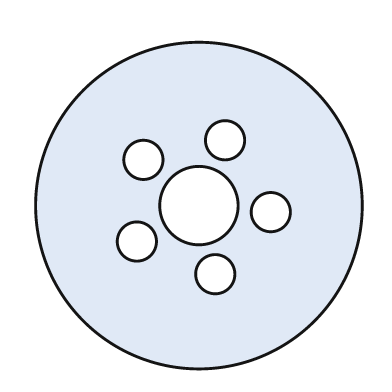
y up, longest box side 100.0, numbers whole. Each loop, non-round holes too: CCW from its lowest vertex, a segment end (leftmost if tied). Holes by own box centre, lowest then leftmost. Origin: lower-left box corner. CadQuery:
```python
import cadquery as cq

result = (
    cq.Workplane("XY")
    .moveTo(50.0, 50.0)
    .circle(50.0)
    .moveTo(55.0, 29.0)
    .circle(6.0)
    .moveTo(31.0, 39.0)
    .circle(6.0)
    .moveTo(72.0, 48.0)
    .circle(6.0)
    .moveTo(50.0, 50.0)
    .circle(12.0)
    .moveTo(33.0, 64.0)
    .circle(6.0)
    .moveTo(58.0, 70.0)
    .circle(6.0)
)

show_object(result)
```